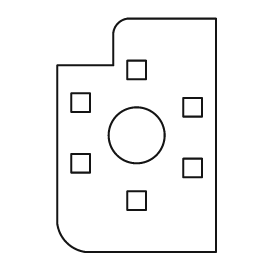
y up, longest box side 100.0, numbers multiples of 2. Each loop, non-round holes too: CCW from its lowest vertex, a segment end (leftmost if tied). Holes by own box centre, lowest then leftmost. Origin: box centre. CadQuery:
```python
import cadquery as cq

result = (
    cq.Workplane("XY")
    .moveTo(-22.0, -50.0)
    .lineTo(34.0, -50.0)
    .lineTo(34.0, 50.0)
    .lineTo(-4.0, 50.0)
    .threePointArc((-8.0, 48.0), (-10.0, 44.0))
    .lineTo(-10.0, 30.0)
    .lineTo(-34.0, 30.0)
    .lineTo(-34.0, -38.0)
    .threePointArc((-30.0, -46.0), (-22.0, -50.0))
    .close()
    .moveTo(-4.0, -32.0)
    .lineTo(4.0, -32.0)
    .lineTo(4.0, -24.0)
    .lineTo(-4.0, -24.0)
    .close()
    .moveTo(20.0, -18.0)
    .lineTo(28.0, -18.0)
    .lineTo(28.0, -10.0)
    .lineTo(20.0, -10.0)
    .close()
    .moveTo(-28.0, -16.0)
    .lineTo(-20.0, -16.0)
    .lineTo(-20.0, -8.0)
    .lineTo(-28.0, -8.0)
    .close()
    .moveTo(0.0, 0.0)
    .circle(12.0)
    .moveTo(20.0, 8.0)
    .lineTo(28.0, 8.0)
    .lineTo(28.0, 16.0)
    .lineTo(20.0, 16.0)
    .close()
    .moveTo(-28.0, 10.0)
    .lineTo(-20.0, 10.0)
    .lineTo(-20.0, 18.0)
    .lineTo(-28.0, 18.0)
    .close()
    .moveTo(-4.0, 24.0)
    .lineTo(4.0, 24.0)
    .lineTo(4.0, 32.0)
    .lineTo(-4.0, 32.0)
    .close()
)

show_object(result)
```